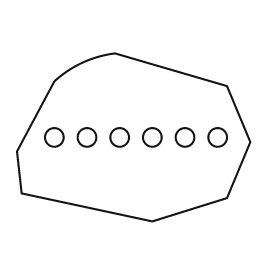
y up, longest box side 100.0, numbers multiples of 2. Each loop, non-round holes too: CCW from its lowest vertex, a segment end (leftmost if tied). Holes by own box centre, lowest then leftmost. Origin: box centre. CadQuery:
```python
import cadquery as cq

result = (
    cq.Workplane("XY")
    .moveTo(8.0, -36.0)
    .lineTo(40.0, -26.0)
    .lineTo(50.0, -2.0)
    .lineTo(40.0, 22.0)
    .lineTo(-8.0, 36.0)
    .threePointArc((-22.0, 32.0), (-34.0, 24.0))
    .lineTo(-50.0, -6.0)
    .lineTo(-48.0, -24.0)
    .close()
    .moveTo(-34.0, 0.0)
    .circle(4.0)
    .moveTo(-20.0, 0.0)
    .circle(4.0)
    .moveTo(-6.0, 0.0)
    .circle(4.0)
    .moveTo(8.0, 0.0)
    .circle(4.0)
    .moveTo(22.0, 0.0)
    .circle(4.0)
    .moveTo(36.0, 0.0)
    .circle(4.0)
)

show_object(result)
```